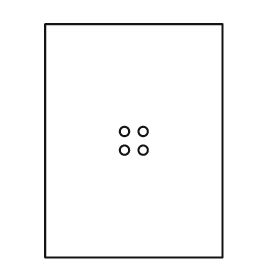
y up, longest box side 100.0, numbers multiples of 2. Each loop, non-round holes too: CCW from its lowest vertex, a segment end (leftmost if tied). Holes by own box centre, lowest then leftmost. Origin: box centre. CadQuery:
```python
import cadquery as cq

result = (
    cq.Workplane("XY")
    .moveTo(-38.0, -50.0)
    .lineTo(38.0, -50.0)
    .lineTo(38.0, 50.0)
    .lineTo(-38.0, 50.0)
    .close()
    .moveTo(-4.0, -4.0)
    .circle(2.0)
    .moveTo(4.0, -4.0)
    .circle(2.0)
    .moveTo(-4.0, 4.0)
    .circle(2.0)
    .moveTo(4.0, 4.0)
    .circle(2.0)
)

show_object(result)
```